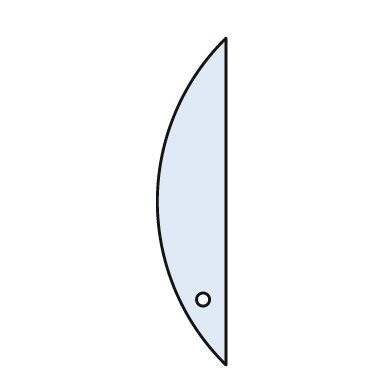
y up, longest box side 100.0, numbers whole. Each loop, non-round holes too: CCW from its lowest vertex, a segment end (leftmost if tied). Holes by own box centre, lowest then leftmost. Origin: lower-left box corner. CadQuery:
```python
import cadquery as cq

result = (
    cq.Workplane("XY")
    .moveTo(21.0, 0.0)
    .lineTo(21.0, 100.0)
    .threePointArc((0.0, 50.0), (21.0, 0.0))
    .close()
    .moveTo(14.0, 20.0)
    .circle(2.0)
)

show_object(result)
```